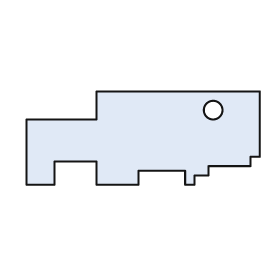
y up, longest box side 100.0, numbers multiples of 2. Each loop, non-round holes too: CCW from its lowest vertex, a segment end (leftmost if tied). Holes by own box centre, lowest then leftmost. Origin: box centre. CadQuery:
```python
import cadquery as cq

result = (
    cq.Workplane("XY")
    .moveTo(-50.0, -20.0)
    .lineTo(-38.0, -20.0)
    .lineTo(-38.0, -10.0)
    .lineTo(-20.0, -10.0)
    .lineTo(-20.0, -20.0)
    .lineTo(-2.0, -20.0)
    .lineTo(-2.0, -14.0)
    .lineTo(18.0, -14.0)
    .lineTo(18.0, -20.0)
    .lineTo(22.0, -20.0)
    .lineTo(22.0, -16.0)
    .lineTo(28.0, -16.0)
    .lineTo(28.0, -12.0)
    .lineTo(46.0, -12.0)
    .lineTo(46.0, -8.0)
    .lineTo(50.0, -8.0)
    .lineTo(50.0, 20.0)
    .lineTo(-20.0, 20.0)
    .lineTo(-20.0, 8.0)
    .lineTo(-50.0, 8.0)
    .close()
    .moveTo(30.0, 12.0)
    .circle(4.0)
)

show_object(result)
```